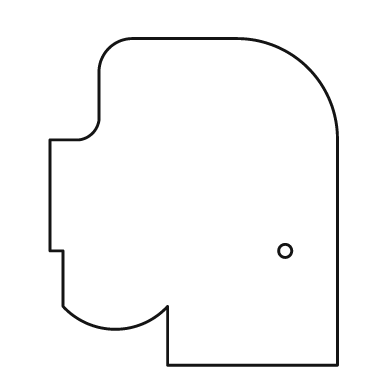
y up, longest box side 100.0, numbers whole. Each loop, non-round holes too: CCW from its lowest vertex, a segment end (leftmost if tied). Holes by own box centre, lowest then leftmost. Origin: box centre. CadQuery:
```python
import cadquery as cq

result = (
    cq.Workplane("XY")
    .moveTo(-8.0, -50.0)
    .lineTo(44.0, -50.0)
    .lineTo(44.0, 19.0)
    .threePointArc((35.0, 41.0), (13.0, 50.0))
    .lineTo(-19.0, 50.0)
    .threePointArc((-26.0, 47.0), (-29.0, 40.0))
    .lineTo(-29.0, 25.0)
    .threePointArc((-31.0, 21.0), (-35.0, 19.0))
    .lineTo(-44.0, 19.0)
    .lineTo(-44.0, -15.0)
    .lineTo(-40.0, -15.0)
    .lineTo(-40.0, -32.0)
    .threePointArc((-24.0, -39.0), (-8.0, -32.0))
    .close()
    .moveTo(28.0, -15.0)
    .circle(2.0)
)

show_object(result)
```